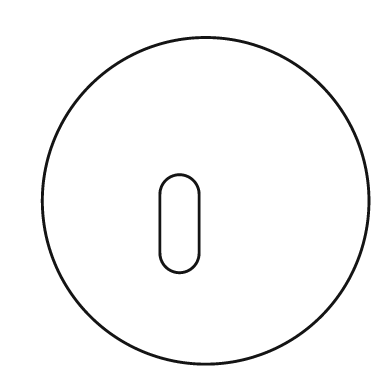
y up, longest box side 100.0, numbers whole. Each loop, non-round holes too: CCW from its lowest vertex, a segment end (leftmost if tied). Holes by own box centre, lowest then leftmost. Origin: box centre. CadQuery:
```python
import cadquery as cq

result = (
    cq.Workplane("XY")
    .moveTo(0.0, 0.0)
    .circle(50.0)
    .moveTo(-14.0, -16.0)
    .threePointArc((-8.0, -22.0), (-2.0, -16.0))
    .lineTo(-2.0, 2.0)
    .threePointArc((-8.0, 8.0), (-14.0, 2.0))
    .close()
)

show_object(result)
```